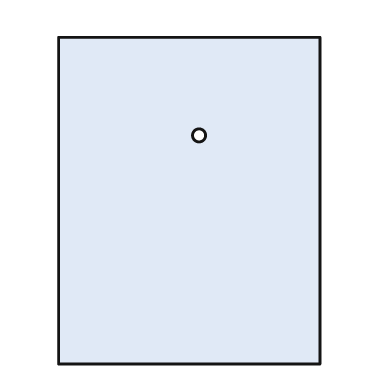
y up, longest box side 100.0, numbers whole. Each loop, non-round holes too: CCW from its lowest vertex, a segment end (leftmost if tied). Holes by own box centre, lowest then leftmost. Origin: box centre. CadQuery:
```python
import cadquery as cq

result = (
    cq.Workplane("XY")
    .moveTo(-40.0, -50.0)
    .lineTo(40.0, -50.0)
    .lineTo(40.0, 50.0)
    .lineTo(-40.0, 50.0)
    .close()
    .moveTo(3.0, 20.0)
    .circle(2.0)
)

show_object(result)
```